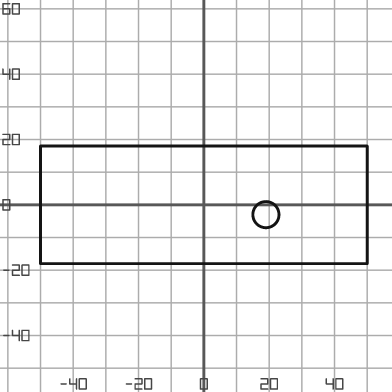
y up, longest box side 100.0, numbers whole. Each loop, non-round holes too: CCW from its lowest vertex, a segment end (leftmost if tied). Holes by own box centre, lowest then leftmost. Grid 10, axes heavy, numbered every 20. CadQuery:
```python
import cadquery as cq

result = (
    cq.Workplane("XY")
    .moveTo(-50.0, -18.0)
    .lineTo(50.0, -18.0)
    .lineTo(50.0, 18.0)
    .lineTo(-50.0, 18.0)
    .close()
    .moveTo(19.0, -3.0)
    .circle(4.0)
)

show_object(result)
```